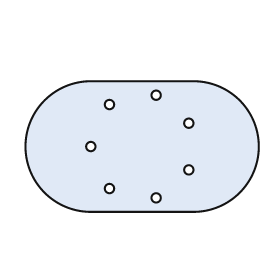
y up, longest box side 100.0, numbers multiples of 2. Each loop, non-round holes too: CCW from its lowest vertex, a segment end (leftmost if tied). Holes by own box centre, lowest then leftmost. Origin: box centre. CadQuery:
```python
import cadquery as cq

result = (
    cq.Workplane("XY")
    .moveTo(-22.0, -28.0)
    .lineTo(22.0, -28.0)
    .threePointArc((50.0, 0.0), (22.0, 28.0))
    .lineTo(-22.0, 28.0)
    .threePointArc((-50.0, 0.0), (-22.0, -28.0))
    .close()
    .moveTo(6.0, -22.0)
    .circle(2.0)
    .moveTo(-14.0, -18.0)
    .circle(2.0)
    .moveTo(20.0, -10.0)
    .circle(2.0)
    .moveTo(-22.0, 0.0)
    .circle(2.0)
    .moveTo(20.0, 10.0)
    .circle(2.0)
    .moveTo(-14.0, 18.0)
    .circle(2.0)
    .moveTo(6.0, 22.0)
    .circle(2.0)
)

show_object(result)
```